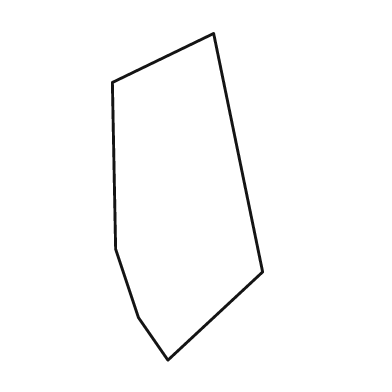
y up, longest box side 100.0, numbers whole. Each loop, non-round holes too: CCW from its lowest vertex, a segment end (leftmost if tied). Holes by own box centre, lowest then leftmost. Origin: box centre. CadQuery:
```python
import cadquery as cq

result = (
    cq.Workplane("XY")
    .moveTo(-6.0, -50.0)
    .lineTo(23.0, -23.0)
    .lineTo(8.0, 50.0)
    .lineTo(-23.0, 35.0)
    .lineTo(-22.0, -16.0)
    .lineTo(-15.0, -37.0)
    .close()
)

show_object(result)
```